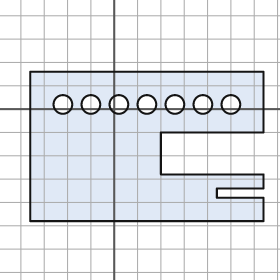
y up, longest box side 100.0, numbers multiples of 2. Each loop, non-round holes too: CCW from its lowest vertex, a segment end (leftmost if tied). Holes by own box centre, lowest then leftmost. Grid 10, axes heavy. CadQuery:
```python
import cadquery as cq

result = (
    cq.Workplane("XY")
    .moveTo(-36.0, -48.0)
    .lineTo(64.0, -48.0)
    .lineTo(64.0, -38.0)
    .lineTo(44.0, -38.0)
    .lineTo(44.0, -34.0)
    .lineTo(64.0, -34.0)
    .lineTo(64.0, -28.0)
    .lineTo(20.0, -28.0)
    .lineTo(20.0, -10.0)
    .lineTo(64.0, -10.0)
    .lineTo(64.0, 16.0)
    .lineTo(-36.0, 16.0)
    .close()
    .moveTo(-22.0, 2.0)
    .circle(4.0)
    .moveTo(-10.0, 2.0)
    .circle(4.0)
    .moveTo(2.0, 2.0)
    .circle(4.0)
    .moveTo(14.0, 2.0)
    .circle(4.0)
    .moveTo(26.0, 2.0)
    .circle(4.0)
    .moveTo(38.0, 2.0)
    .circle(4.0)
    .moveTo(50.0, 2.0)
    .circle(4.0)
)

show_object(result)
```